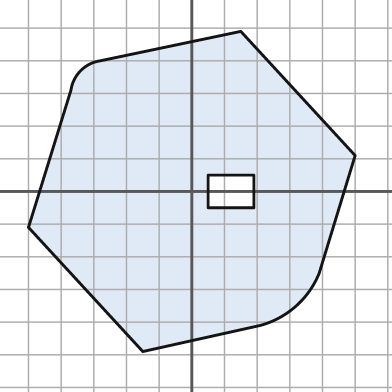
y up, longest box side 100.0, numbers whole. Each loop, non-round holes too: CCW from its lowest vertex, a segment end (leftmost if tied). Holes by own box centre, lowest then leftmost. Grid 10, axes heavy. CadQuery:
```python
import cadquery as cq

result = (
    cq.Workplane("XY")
    .moveTo(-15.0, -49.0)
    .lineTo(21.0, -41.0)
    .threePointArc((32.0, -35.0), (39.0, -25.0))
    .lineTo(50.0, 11.0)
    .lineTo(15.0, 49.0)
    .lineTo(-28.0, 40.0)
    .threePointArc((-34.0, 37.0), (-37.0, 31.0))
    .lineTo(-50.0, -11.0)
    .close()
    .moveTo(5.0, -5.0)
    .lineTo(19.0, -5.0)
    .lineTo(19.0, 5.0)
    .lineTo(5.0, 5.0)
    .close()
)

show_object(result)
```